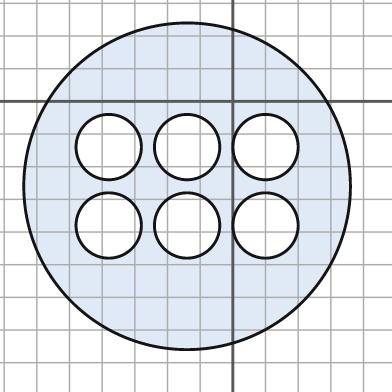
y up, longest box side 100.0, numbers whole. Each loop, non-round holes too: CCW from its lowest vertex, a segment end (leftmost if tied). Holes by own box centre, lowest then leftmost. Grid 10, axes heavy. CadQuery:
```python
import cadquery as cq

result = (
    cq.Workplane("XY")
    .moveTo(-14.0, -26.0)
    .circle(50.0)
    .moveTo(-38.0, -38.0)
    .circle(10.0)
    .moveTo(-14.0, -38.0)
    .circle(10.0)
    .moveTo(10.0, -38.0)
    .circle(10.0)
    .moveTo(-38.0, -14.0)
    .circle(10.0)
    .moveTo(-14.0, -14.0)
    .circle(10.0)
    .moveTo(10.0, -14.0)
    .circle(10.0)
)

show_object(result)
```